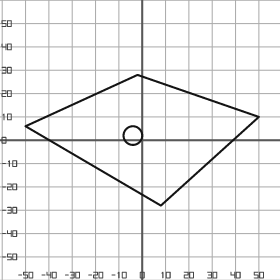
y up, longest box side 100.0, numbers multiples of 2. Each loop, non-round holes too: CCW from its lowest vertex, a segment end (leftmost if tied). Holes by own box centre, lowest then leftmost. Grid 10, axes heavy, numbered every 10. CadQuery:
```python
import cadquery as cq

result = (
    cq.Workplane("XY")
    .moveTo(8.0, -28.0)
    .lineTo(50.0, 10.0)
    .lineTo(-2.0, 28.0)
    .lineTo(-50.0, 6.0)
    .close()
    .moveTo(-4.0, 2.0)
    .circle(4.0)
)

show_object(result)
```